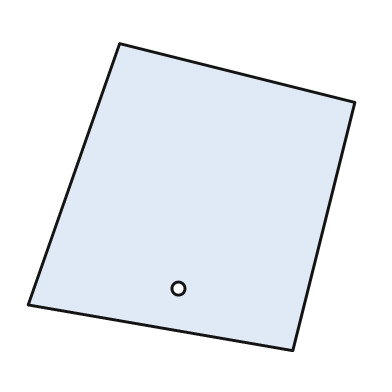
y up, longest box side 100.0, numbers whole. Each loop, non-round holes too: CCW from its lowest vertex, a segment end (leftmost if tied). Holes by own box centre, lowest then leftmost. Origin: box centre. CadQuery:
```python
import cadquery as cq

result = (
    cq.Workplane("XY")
    .moveTo(31.0, -47.0)
    .lineTo(50.0, 29.0)
    .lineTo(-22.0, 47.0)
    .lineTo(-50.0, -33.0)
    .close()
    .moveTo(-4.0, -28.0)
    .circle(2.0)
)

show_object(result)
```